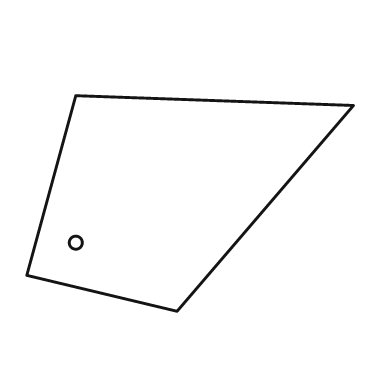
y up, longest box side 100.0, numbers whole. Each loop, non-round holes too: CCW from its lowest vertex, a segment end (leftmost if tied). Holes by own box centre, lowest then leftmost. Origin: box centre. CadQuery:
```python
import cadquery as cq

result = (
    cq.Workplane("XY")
    .moveTo(-4.0, -33.0)
    .lineTo(50.0, 30.0)
    .lineTo(-35.0, 33.0)
    .lineTo(-50.0, -22.0)
    .close()
    .moveTo(-35.0, -12.0)
    .circle(2.0)
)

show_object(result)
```